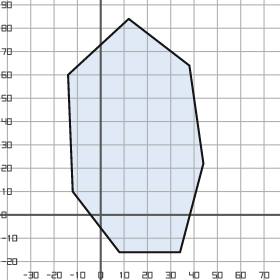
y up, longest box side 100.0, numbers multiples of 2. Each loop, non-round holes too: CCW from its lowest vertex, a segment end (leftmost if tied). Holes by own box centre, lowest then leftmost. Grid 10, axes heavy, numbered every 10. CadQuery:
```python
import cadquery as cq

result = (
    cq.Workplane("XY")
    .moveTo(8.0, -16.0)
    .lineTo(34.0, -16.0)
    .lineTo(44.0, 22.0)
    .lineTo(38.0, 64.0)
    .lineTo(12.0, 84.0)
    .lineTo(-14.0, 60.0)
    .lineTo(-12.0, 10.0)
    .close()
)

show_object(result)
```